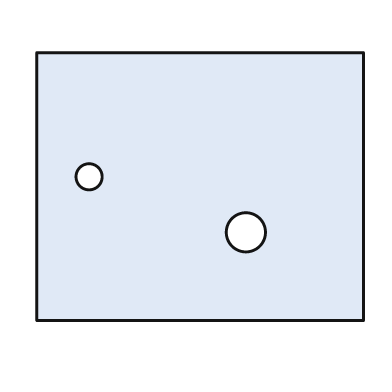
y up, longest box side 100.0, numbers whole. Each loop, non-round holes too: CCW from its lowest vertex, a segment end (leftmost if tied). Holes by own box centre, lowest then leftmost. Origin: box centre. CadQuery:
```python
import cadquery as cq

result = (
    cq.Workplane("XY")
    .moveTo(-50.0, -41.0)
    .lineTo(50.0, -41.0)
    .lineTo(50.0, 41.0)
    .lineTo(-50.0, 41.0)
    .close()
    .moveTo(14.0, -14.0)
    .circle(6.0)
    .moveTo(-34.0, 3.0)
    .circle(4.0)
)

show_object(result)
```